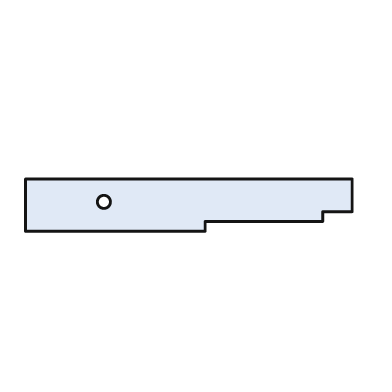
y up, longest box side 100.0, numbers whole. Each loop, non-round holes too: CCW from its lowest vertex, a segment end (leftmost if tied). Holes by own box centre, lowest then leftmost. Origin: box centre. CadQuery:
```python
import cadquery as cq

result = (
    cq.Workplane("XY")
    .moveTo(-50.0, -8.0)
    .lineTo(5.0, -8.0)
    .lineTo(5.0, -5.0)
    .lineTo(41.0, -5.0)
    .lineTo(41.0, -2.0)
    .lineTo(50.0, -2.0)
    .lineTo(50.0, 8.0)
    .lineTo(-50.0, 8.0)
    .close()
    .moveTo(-26.0, 1.0)
    .circle(2.0)
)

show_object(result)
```